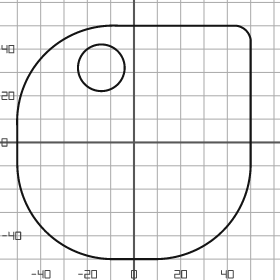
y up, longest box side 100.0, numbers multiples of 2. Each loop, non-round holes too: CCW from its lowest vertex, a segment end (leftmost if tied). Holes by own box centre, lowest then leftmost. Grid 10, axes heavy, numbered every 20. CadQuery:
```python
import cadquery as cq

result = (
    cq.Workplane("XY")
    .moveTo(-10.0, -50.0)
    .lineTo(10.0, -50.0)
    .threePointArc((38.0, -38.0), (50.0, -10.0))
    .lineTo(50.0, 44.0)
    .threePointArc((48.0, 48.0), (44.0, 50.0))
    .lineTo(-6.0, 50.0)
    .threePointArc((-38.0, 38.0), (-50.0, 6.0))
    .lineTo(-50.0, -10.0)
    .threePointArc((-38.0, -38.0), (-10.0, -50.0))
    .close()
    .moveTo(-14.0, 32.0)
    .circle(10.0)
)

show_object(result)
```